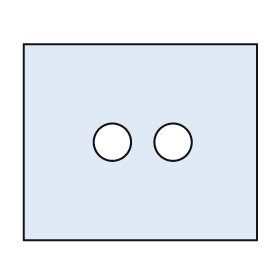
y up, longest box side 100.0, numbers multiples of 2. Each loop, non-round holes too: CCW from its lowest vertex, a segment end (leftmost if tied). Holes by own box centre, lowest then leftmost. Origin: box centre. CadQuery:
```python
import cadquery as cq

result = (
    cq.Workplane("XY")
    .moveTo(-50.0, -42.0)
    .lineTo(50.0, -42.0)
    .lineTo(50.0, 42.0)
    .lineTo(-50.0, 42.0)
    .close()
    .moveTo(-12.0, 0.0)
    .circle(8.0)
    .moveTo(14.0, 0.0)
    .circle(8.0)
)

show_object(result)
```